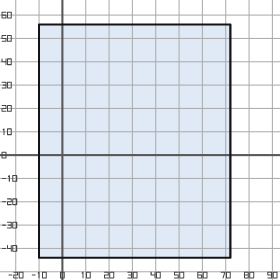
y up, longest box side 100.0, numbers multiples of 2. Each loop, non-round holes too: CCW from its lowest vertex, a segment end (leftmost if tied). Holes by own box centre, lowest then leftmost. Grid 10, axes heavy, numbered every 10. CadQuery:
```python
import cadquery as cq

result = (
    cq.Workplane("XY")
    .moveTo(-10.0, -44.0)
    .lineTo(72.0, -44.0)
    .lineTo(72.0, 56.0)
    .lineTo(-10.0, 56.0)
    .close()
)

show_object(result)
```